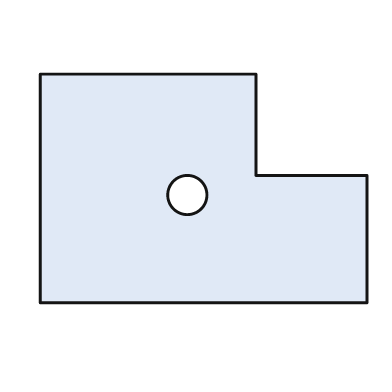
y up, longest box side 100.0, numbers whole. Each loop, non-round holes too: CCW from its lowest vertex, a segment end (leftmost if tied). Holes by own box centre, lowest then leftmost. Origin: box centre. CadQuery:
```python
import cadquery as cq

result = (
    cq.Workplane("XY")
    .moveTo(-50.0, -35.0)
    .lineTo(50.0, -35.0)
    .lineTo(50.0, 4.0)
    .lineTo(16.0, 4.0)
    .lineTo(16.0, 35.0)
    .lineTo(-50.0, 35.0)
    .close()
    .moveTo(-5.0, -2.0)
    .circle(6.0)
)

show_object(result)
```